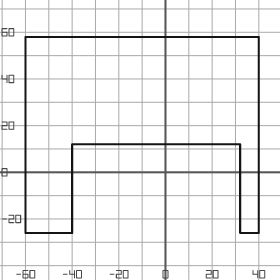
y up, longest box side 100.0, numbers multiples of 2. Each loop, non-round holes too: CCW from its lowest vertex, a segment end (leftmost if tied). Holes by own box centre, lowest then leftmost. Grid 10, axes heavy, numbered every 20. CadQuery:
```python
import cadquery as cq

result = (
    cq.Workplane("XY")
    .moveTo(-60.0, -26.0)
    .lineTo(-40.0, -26.0)
    .lineTo(-40.0, 12.0)
    .lineTo(32.0, 12.0)
    .lineTo(32.0, -26.0)
    .lineTo(40.0, -26.0)
    .lineTo(40.0, 58.0)
    .lineTo(-60.0, 58.0)
    .close()
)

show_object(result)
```